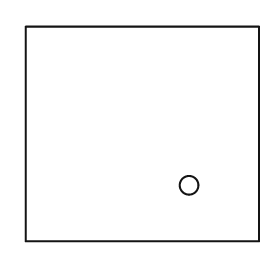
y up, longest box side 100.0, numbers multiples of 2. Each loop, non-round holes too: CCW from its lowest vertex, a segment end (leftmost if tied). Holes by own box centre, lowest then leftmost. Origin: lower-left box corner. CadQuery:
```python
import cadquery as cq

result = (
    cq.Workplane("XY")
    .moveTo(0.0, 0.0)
    .lineTo(100.0, 0.0)
    .lineTo(100.0, 92.0)
    .lineTo(0.0, 92.0)
    .close()
    .moveTo(70.0, 24.0)
    .circle(4.0)
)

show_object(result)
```